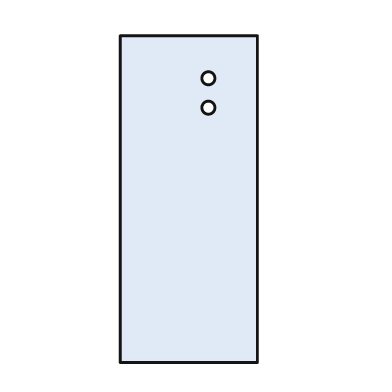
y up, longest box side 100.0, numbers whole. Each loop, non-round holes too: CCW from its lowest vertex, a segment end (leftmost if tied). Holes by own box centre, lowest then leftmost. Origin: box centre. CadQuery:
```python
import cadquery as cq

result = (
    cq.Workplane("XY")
    .moveTo(-21.0, -50.0)
    .lineTo(21.0, -50.0)
    .lineTo(21.0, 50.0)
    .lineTo(-21.0, 50.0)
    .close()
    .moveTo(6.0, 28.0)
    .circle(2.0)
    .moveTo(6.0, 37.0)
    .circle(2.0)
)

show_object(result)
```